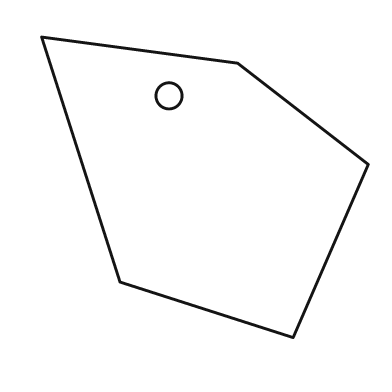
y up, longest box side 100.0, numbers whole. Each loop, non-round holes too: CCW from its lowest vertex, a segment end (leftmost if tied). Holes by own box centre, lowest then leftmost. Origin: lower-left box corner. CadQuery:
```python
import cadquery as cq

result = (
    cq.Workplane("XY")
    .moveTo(77.0, 0.0)
    .lineTo(100.0, 53.0)
    .lineTo(60.0, 84.0)
    .lineTo(0.0, 92.0)
    .lineTo(24.0, 17.0)
    .close()
    .moveTo(39.0, 74.0)
    .circle(4.0)
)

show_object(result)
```